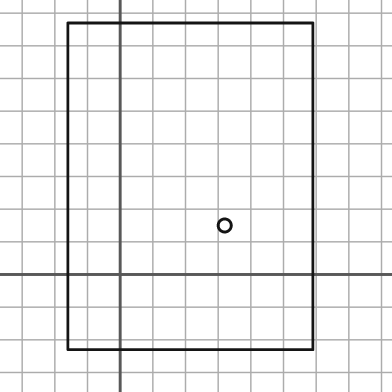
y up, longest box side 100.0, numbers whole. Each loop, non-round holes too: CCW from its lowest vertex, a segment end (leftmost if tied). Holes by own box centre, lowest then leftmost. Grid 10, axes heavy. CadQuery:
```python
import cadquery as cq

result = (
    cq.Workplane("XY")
    .moveTo(-16.0, -23.0)
    .lineTo(59.0, -23.0)
    .lineTo(59.0, 77.0)
    .lineTo(-16.0, 77.0)
    .close()
    .moveTo(32.0, 15.0)
    .circle(2.0)
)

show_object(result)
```